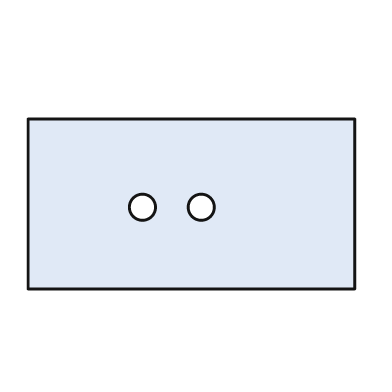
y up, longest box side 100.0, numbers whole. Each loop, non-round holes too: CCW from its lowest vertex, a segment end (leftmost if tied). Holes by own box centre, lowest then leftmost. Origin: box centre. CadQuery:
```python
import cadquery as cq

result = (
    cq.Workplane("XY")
    .moveTo(-50.0, -26.0)
    .lineTo(50.0, -26.0)
    .lineTo(50.0, 26.0)
    .lineTo(-50.0, 26.0)
    .close()
    .moveTo(-15.0, -1.0)
    .circle(4.0)
    .moveTo(3.0, -1.0)
    .circle(4.0)
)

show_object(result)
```